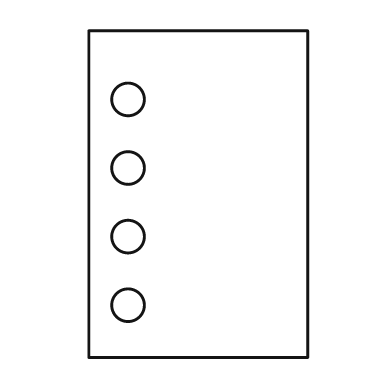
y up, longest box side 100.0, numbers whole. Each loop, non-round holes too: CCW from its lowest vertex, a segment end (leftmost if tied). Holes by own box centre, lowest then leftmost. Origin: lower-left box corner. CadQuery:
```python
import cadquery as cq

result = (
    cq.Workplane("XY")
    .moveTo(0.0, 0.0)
    .lineTo(67.0, 0.0)
    .lineTo(67.0, 100.0)
    .lineTo(0.0, 100.0)
    .close()
    .moveTo(12.0, 16.0)
    .circle(5.0)
    .moveTo(12.0, 37.0)
    .circle(5.0)
    .moveTo(12.0, 58.0)
    .circle(5.0)
    .moveTo(12.0, 79.0)
    .circle(5.0)
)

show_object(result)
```